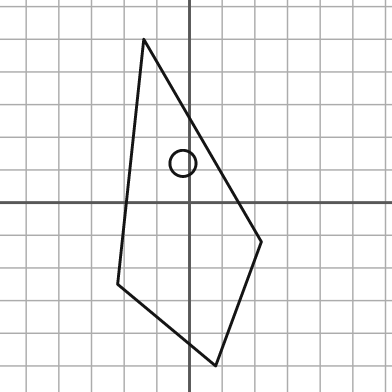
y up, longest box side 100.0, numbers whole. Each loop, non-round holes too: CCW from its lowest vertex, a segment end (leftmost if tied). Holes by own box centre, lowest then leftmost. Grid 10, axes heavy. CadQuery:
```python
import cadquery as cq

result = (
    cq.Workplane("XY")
    .moveTo(8.0, -50.0)
    .lineTo(22.0, -12.0)
    .lineTo(-14.0, 50.0)
    .lineTo(-22.0, -25.0)
    .close()
    .moveTo(-2.0, 12.0)
    .circle(4.0)
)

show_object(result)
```